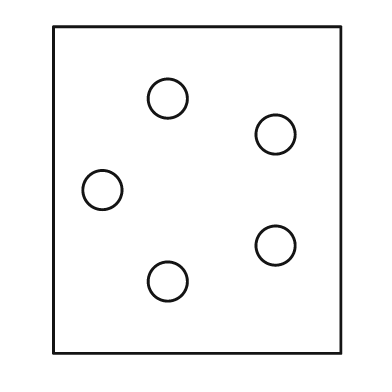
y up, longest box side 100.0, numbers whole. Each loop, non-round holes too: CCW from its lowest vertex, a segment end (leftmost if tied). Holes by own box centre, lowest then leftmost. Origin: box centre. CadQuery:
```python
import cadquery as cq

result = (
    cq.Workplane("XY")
    .moveTo(-44.0, -50.0)
    .lineTo(44.0, -50.0)
    .lineTo(44.0, 50.0)
    .lineTo(-44.0, 50.0)
    .close()
    .moveTo(-9.0, -28.0)
    .circle(6.0)
    .moveTo(24.0, -17.0)
    .circle(6.0)
    .moveTo(-29.0, 0.0)
    .circle(6.0)
    .moveTo(24.0, 17.0)
    .circle(6.0)
    .moveTo(-9.0, 28.0)
    .circle(6.0)
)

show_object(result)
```